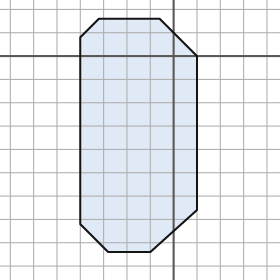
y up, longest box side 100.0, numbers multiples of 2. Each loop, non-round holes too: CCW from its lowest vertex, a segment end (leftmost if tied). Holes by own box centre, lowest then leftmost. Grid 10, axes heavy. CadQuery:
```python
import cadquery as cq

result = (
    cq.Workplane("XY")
    .moveTo(-28.0, -84.0)
    .lineTo(-10.0, -84.0)
    .lineTo(10.0, -66.0)
    .lineTo(10.0, 0.0)
    .lineTo(-6.0, 16.0)
    .lineTo(-32.0, 16.0)
    .lineTo(-40.0, 8.0)
    .lineTo(-40.0, -72.0)
    .close()
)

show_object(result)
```